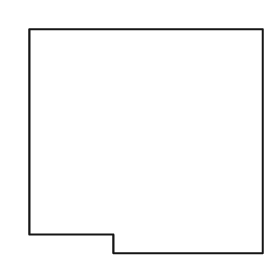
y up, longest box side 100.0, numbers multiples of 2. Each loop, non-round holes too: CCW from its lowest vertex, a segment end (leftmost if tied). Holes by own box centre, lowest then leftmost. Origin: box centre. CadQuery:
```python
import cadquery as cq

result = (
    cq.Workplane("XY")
    .moveTo(-14.0, -48.0)
    .lineTo(50.0, -48.0)
    .lineTo(50.0, 48.0)
    .lineTo(-50.0, 48.0)
    .lineTo(-50.0, -40.0)
    .lineTo(-14.0, -40.0)
    .close()
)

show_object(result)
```